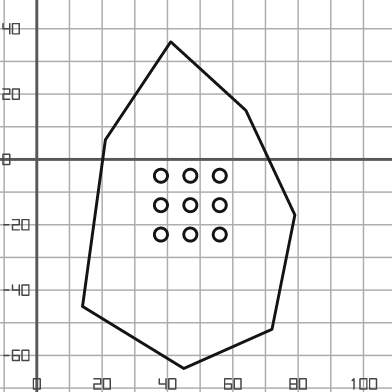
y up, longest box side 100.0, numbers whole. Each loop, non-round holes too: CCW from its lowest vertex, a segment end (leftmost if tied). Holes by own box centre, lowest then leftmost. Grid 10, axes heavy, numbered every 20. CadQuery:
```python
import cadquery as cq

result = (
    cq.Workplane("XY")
    .moveTo(45.0, -64.0)
    .lineTo(72.0, -52.0)
    .lineTo(79.0, -17.0)
    .lineTo(64.0, 15.0)
    .lineTo(41.0, 36.0)
    .lineTo(21.0, 6.0)
    .lineTo(14.0, -45.0)
    .close()
    .moveTo(38.0, -23.0)
    .circle(2.0)
    .moveTo(47.0, -23.0)
    .circle(2.0)
    .moveTo(56.0, -23.0)
    .circle(2.0)
    .moveTo(38.0, -14.0)
    .circle(2.0)
    .moveTo(47.0, -14.0)
    .circle(2.0)
    .moveTo(56.0, -14.0)
    .circle(2.0)
    .moveTo(38.0, -5.0)
    .circle(2.0)
    .moveTo(47.0, -5.0)
    .circle(2.0)
    .moveTo(56.0, -5.0)
    .circle(2.0)
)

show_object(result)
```